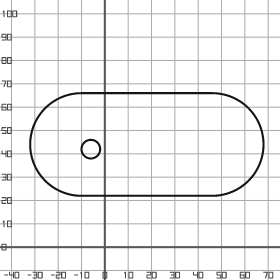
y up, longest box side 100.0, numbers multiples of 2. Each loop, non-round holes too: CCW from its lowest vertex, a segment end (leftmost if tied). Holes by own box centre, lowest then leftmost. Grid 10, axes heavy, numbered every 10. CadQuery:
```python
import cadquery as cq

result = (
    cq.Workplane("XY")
    .moveTo(-10.0, 22.0)
    .lineTo(46.0, 22.0)
    .threePointArc((68.0, 44.0), (46.0, 66.0))
    .lineTo(-10.0, 66.0)
    .threePointArc((-32.0, 44.0), (-10.0, 22.0))
    .close()
    .moveTo(-6.0, 42.0)
    .circle(4.0)
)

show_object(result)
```